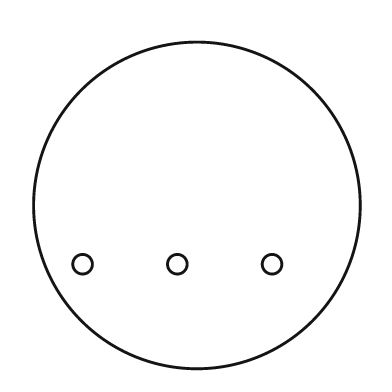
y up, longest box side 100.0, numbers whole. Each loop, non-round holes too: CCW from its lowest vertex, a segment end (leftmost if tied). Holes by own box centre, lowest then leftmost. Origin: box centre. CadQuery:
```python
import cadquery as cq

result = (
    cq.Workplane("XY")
    .moveTo(0.0, 0.0)
    .circle(50.0)
    .moveTo(-35.0, -18.0)
    .circle(3.0)
    .moveTo(-6.0, -18.0)
    .circle(3.0)
    .moveTo(23.0, -18.0)
    .circle(3.0)
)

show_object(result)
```